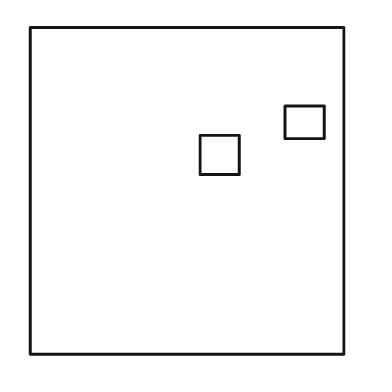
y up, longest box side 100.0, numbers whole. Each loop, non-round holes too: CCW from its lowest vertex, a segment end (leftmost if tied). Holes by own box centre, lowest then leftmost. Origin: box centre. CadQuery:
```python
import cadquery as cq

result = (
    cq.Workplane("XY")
    .moveTo(-48.0, -50.0)
    .lineTo(48.0, -50.0)
    .lineTo(48.0, 50.0)
    .lineTo(-48.0, 50.0)
    .close()
    .moveTo(4.0, 5.0)
    .lineTo(16.0, 5.0)
    .lineTo(16.0, 17.0)
    .lineTo(4.0, 17.0)
    .close()
    .moveTo(30.0, 16.0)
    .lineTo(42.0, 16.0)
    .lineTo(42.0, 26.0)
    .lineTo(30.0, 26.0)
    .close()
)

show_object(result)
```